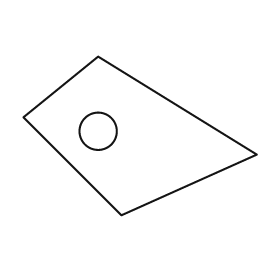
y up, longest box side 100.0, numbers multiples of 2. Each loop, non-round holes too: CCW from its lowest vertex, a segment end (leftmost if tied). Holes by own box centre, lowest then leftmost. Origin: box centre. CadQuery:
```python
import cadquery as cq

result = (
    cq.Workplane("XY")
    .moveTo(-8.0, -34.0)
    .lineTo(50.0, -8.0)
    .lineTo(-18.0, 34.0)
    .lineTo(-50.0, 8.0)
    .close()
    .moveTo(-18.0, 2.0)
    .circle(8.0)
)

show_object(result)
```